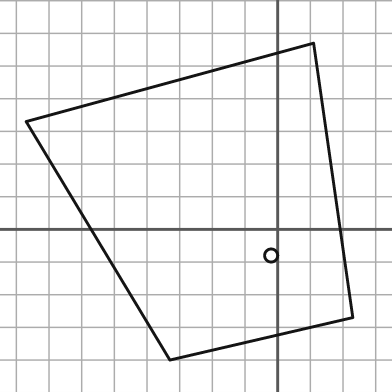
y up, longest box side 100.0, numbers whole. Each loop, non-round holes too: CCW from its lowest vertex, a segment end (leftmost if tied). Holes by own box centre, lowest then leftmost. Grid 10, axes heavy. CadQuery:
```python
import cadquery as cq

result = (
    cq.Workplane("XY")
    .moveTo(-33.0, -40.0)
    .lineTo(23.0, -27.0)
    .lineTo(11.0, 57.0)
    .lineTo(-77.0, 33.0)
    .close()
    .moveTo(-2.0, -8.0)
    .circle(2.0)
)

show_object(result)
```